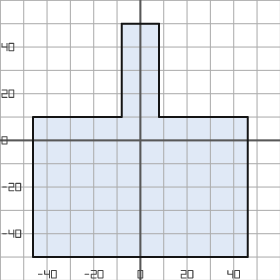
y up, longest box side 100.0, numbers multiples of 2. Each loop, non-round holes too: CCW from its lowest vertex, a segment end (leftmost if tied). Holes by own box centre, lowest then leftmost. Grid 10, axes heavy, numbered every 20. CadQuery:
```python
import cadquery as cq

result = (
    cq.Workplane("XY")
    .moveTo(-46.0, -50.0)
    .lineTo(46.0, -50.0)
    .lineTo(46.0, 10.0)
    .lineTo(8.0, 10.0)
    .lineTo(8.0, 50.0)
    .lineTo(-8.0, 50.0)
    .lineTo(-8.0, 10.0)
    .lineTo(-46.0, 10.0)
    .close()
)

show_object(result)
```